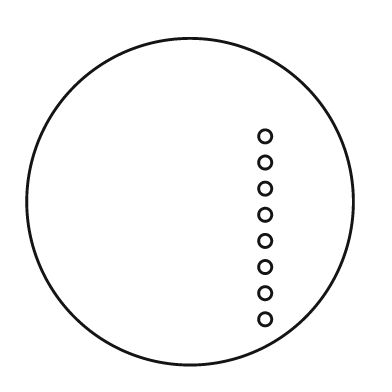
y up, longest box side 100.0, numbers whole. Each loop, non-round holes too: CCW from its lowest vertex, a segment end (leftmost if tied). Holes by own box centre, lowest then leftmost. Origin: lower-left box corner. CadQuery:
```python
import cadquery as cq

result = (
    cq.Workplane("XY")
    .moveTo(50.0, 50.0)
    .circle(50.0)
    .moveTo(73.0, 14.0)
    .circle(2.0)
    .moveTo(73.0, 22.0)
    .circle(2.0)
    .moveTo(73.0, 30.0)
    .circle(2.0)
    .moveTo(73.0, 38.0)
    .circle(2.0)
    .moveTo(73.0, 46.0)
    .circle(2.0)
    .moveTo(73.0, 54.0)
    .circle(2.0)
    .moveTo(73.0, 62.0)
    .circle(2.0)
    .moveTo(73.0, 70.0)
    .circle(2.0)
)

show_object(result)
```